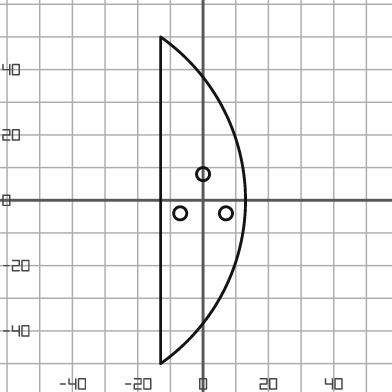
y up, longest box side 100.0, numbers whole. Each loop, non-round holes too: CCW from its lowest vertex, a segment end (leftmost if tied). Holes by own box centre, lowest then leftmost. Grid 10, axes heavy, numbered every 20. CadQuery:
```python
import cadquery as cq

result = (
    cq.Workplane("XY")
    .moveTo(-13.0, -50.0)
    .threePointArc((13.0, 0.0), (-13.0, 50.0))
    .close()
    .moveTo(-7.0, -4.0)
    .circle(2.0)
    .moveTo(7.0, -4.0)
    .circle(2.0)
    .moveTo(0.0, 8.0)
    .circle(2.0)
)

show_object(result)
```